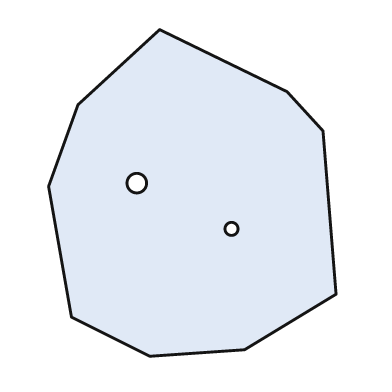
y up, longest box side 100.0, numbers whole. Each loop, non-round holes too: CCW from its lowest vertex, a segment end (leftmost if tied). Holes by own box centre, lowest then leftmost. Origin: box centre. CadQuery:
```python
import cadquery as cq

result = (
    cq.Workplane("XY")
    .moveTo(-13.0, -50.0)
    .lineTo(16.0, -48.0)
    .lineTo(44.0, -31.0)
    .lineTo(40.0, 19.0)
    .lineTo(29.0, 31.0)
    .lineTo(-10.0, 50.0)
    .lineTo(-35.0, 27.0)
    .lineTo(-44.0, 2.0)
    .lineTo(-37.0, -38.0)
    .close()
    .moveTo(12.0, -11.0)
    .circle(2.0)
    .moveTo(-17.0, 3.0)
    .circle(3.0)
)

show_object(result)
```